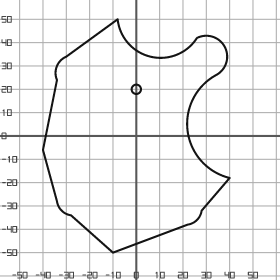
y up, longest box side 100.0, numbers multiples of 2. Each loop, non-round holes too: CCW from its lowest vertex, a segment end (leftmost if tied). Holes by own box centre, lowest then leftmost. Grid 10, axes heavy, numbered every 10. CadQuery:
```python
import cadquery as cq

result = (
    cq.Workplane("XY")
    .moveTo(-10.0, -50.0)
    .lineTo(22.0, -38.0)
    .threePointArc((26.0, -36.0), (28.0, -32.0))
    .lineTo(40.0, -18.0)
    .threePointArc((22.0, 2.0), (34.0, 26.0))
    .threePointArc((38.0, 38.0), (26.0, 42.0))
    .threePointArc((6.0, 34.0), (-8.0, 50.0))
    .lineTo(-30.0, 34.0)
    .threePointArc((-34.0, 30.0), (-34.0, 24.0))
    .lineTo(-40.0, -6.0)
    .lineTo(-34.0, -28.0)
    .threePointArc((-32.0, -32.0), (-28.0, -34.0))
    .close()
    .moveTo(0.0, 20.0)
    .circle(2.0)
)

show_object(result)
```